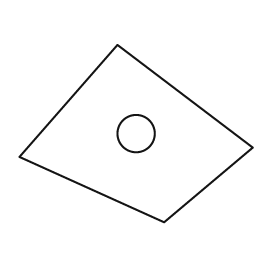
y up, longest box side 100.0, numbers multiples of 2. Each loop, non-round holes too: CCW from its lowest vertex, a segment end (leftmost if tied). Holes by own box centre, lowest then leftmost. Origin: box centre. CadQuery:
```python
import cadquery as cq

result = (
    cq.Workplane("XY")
    .moveTo(12.0, -38.0)
    .lineTo(50.0, -6.0)
    .lineTo(-8.0, 38.0)
    .lineTo(-50.0, -10.0)
    .close()
    .moveTo(0.0, 0.0)
    .circle(8.0)
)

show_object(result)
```